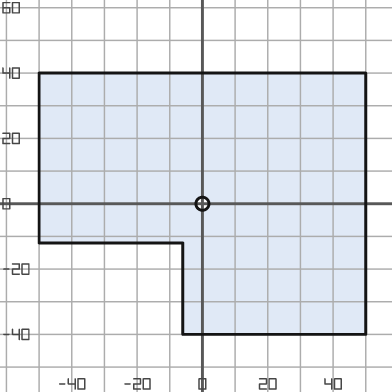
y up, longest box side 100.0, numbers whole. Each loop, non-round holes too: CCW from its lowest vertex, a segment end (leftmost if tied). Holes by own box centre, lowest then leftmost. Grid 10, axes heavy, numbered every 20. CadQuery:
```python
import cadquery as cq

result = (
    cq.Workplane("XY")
    .moveTo(-6.0, -40.0)
    .lineTo(50.0, -40.0)
    .lineTo(50.0, 40.0)
    .lineTo(-50.0, 40.0)
    .lineTo(-50.0, -12.0)
    .lineTo(-6.0, -12.0)
    .close()
    .moveTo(0.0, 0.0)
    .circle(2.0)
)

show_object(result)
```